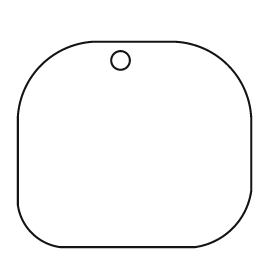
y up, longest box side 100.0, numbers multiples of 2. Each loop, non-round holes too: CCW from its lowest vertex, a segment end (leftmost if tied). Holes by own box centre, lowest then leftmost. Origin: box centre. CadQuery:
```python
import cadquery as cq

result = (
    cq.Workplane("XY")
    .moveTo(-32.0, -44.0)
    .lineTo(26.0, -44.0)
    .threePointArc((42.0, -36.0), (50.0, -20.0))
    .lineTo(50.0, 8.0)
    .threePointArc((40.0, 34.0), (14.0, 44.0))
    .lineTo(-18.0, 44.0)
    .threePointArc((-40.0, 34.0), (-50.0, 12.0))
    .lineTo(-50.0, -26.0)
    .threePointArc((-44.0, -38.0), (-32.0, -44.0))
    .close()
    .moveTo(-6.0, 36.0)
    .circle(4.0)
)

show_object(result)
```